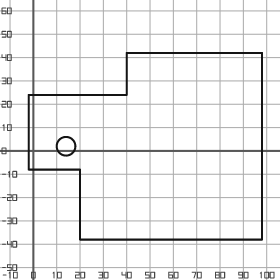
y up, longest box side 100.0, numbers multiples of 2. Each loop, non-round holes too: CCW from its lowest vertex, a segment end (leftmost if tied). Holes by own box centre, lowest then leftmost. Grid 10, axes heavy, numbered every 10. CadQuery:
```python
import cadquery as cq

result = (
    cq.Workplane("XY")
    .moveTo(20.0, -38.0)
    .lineTo(98.0, -38.0)
    .lineTo(98.0, 42.0)
    .lineTo(40.0, 42.0)
    .lineTo(40.0, 24.0)
    .lineTo(-2.0, 24.0)
    .lineTo(-2.0, -8.0)
    .lineTo(20.0, -8.0)
    .close()
    .moveTo(14.0, 2.0)
    .circle(4.0)
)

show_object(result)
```